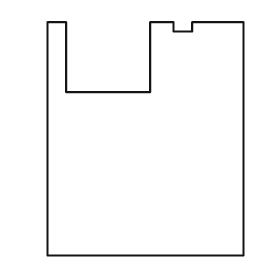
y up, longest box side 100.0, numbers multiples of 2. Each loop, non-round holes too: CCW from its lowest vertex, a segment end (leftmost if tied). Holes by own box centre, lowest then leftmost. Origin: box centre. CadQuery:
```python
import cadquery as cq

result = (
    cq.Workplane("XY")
    .moveTo(-42.0, -50.0)
    .lineTo(42.0, -50.0)
    .lineTo(42.0, 50.0)
    .lineTo(20.0, 50.0)
    .lineTo(20.0, 46.0)
    .lineTo(12.0, 46.0)
    .lineTo(12.0, 50.0)
    .lineTo(2.0, 50.0)
    .lineTo(2.0, 20.0)
    .lineTo(-34.0, 20.0)
    .lineTo(-34.0, 50.0)
    .lineTo(-42.0, 50.0)
    .close()
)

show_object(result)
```